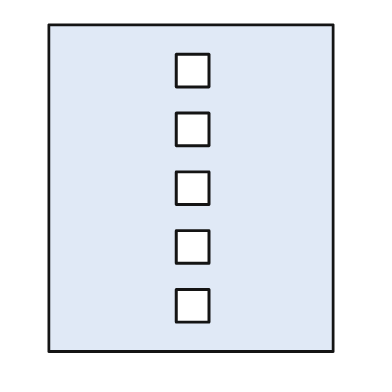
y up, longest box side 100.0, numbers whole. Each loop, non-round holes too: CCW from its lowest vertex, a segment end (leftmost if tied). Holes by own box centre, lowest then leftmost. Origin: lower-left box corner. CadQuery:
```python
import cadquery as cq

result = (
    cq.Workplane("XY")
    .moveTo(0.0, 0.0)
    .lineTo(87.0, 0.0)
    .lineTo(87.0, 100.0)
    .lineTo(0.0, 100.0)
    .close()
    .moveTo(39.0, 9.0)
    .lineTo(49.0, 9.0)
    .lineTo(49.0, 19.0)
    .lineTo(39.0, 19.0)
    .close()
    .moveTo(39.0, 27.0)
    .lineTo(49.0, 27.0)
    .lineTo(49.0, 37.0)
    .lineTo(39.0, 37.0)
    .close()
    .moveTo(39.0, 45.0)
    .lineTo(49.0, 45.0)
    .lineTo(49.0, 55.0)
    .lineTo(39.0, 55.0)
    .close()
    .moveTo(39.0, 63.0)
    .lineTo(49.0, 63.0)
    .lineTo(49.0, 73.0)
    .lineTo(39.0, 73.0)
    .close()
    .moveTo(39.0, 81.0)
    .lineTo(49.0, 81.0)
    .lineTo(49.0, 91.0)
    .lineTo(39.0, 91.0)
    .close()
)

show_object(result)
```